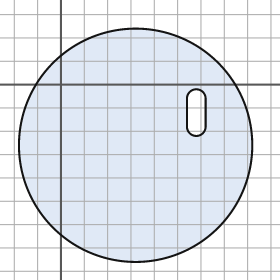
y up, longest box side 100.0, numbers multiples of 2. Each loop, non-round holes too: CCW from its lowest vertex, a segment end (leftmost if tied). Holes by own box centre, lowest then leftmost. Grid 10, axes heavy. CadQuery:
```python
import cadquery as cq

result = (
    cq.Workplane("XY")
    .moveTo(32.0, -26.0)
    .circle(50.0)
    .moveTo(54.0, -18.0)
    .threePointArc((58.0, -22.0), (62.0, -18.0))
    .lineTo(62.0, -6.0)
    .threePointArc((58.0, -2.0), (54.0, -6.0))
    .close()
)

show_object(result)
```